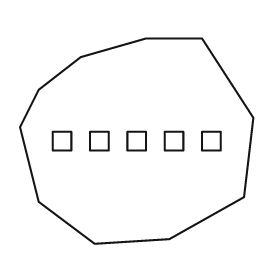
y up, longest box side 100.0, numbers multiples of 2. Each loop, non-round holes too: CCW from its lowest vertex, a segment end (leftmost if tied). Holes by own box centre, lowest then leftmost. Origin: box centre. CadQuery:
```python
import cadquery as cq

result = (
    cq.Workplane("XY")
    .moveTo(-18.0, -44.0)
    .lineTo(14.0, -42.0)
    .lineTo(46.0, -24.0)
    .lineTo(50.0, 10.0)
    .lineTo(28.0, 44.0)
    .lineTo(4.0, 44.0)
    .lineTo(-24.0, 36.0)
    .lineTo(-42.0, 22.0)
    .lineTo(-50.0, 6.0)
    .lineTo(-42.0, -26.0)
    .close()
    .moveTo(-36.0, -4.0)
    .lineTo(-28.0, -4.0)
    .lineTo(-28.0, 4.0)
    .lineTo(-36.0, 4.0)
    .close()
    .moveTo(-20.0, -4.0)
    .lineTo(-12.0, -4.0)
    .lineTo(-12.0, 4.0)
    .lineTo(-20.0, 4.0)
    .close()
    .moveTo(-4.0, -4.0)
    .lineTo(4.0, -4.0)
    .lineTo(4.0, 4.0)
    .lineTo(-4.0, 4.0)
    .close()
    .moveTo(12.0, -4.0)
    .lineTo(20.0, -4.0)
    .lineTo(20.0, 4.0)
    .lineTo(12.0, 4.0)
    .close()
    .moveTo(28.0, -4.0)
    .lineTo(36.0, -4.0)
    .lineTo(36.0, 4.0)
    .lineTo(28.0, 4.0)
    .close()
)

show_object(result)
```